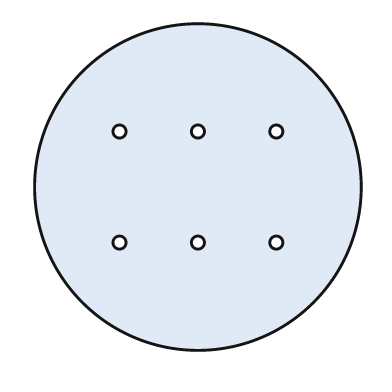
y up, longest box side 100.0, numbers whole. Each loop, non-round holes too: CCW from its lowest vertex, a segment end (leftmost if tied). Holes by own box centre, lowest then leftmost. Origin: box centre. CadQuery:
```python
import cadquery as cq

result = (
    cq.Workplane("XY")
    .moveTo(0.0, 0.0)
    .circle(50.0)
    .moveTo(-24.0, -17.0)
    .circle(2.0)
    .moveTo(0.0, -17.0)
    .circle(2.0)
    .moveTo(24.0, -17.0)
    .circle(2.0)
    .moveTo(-24.0, 17.0)
    .circle(2.0)
    .moveTo(0.0, 17.0)
    .circle(2.0)
    .moveTo(24.0, 17.0)
    .circle(2.0)
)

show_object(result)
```